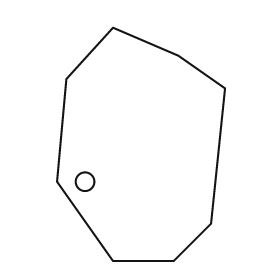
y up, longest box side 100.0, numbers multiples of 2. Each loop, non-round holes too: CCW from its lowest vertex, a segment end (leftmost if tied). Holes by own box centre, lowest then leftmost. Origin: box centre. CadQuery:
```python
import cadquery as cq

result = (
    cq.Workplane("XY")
    .moveTo(-12.0, -50.0)
    .lineTo(14.0, -50.0)
    .lineTo(30.0, -34.0)
    .lineTo(36.0, 24.0)
    .lineTo(16.0, 38.0)
    .lineTo(-12.0, 50.0)
    .lineTo(-32.0, 28.0)
    .lineTo(-36.0, -16.0)
    .close()
    .moveTo(-24.0, -16.0)
    .circle(4.0)
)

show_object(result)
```